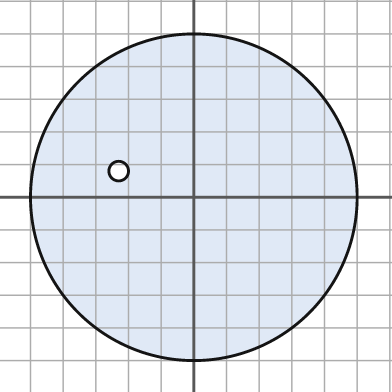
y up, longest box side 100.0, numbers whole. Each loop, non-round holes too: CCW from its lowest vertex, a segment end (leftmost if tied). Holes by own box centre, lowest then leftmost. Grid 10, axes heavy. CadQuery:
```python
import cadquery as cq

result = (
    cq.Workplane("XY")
    .moveTo(0.0, 0.0)
    .circle(50.0)
    .moveTo(-23.0, 8.0)
    .circle(3.0)
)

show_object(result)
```